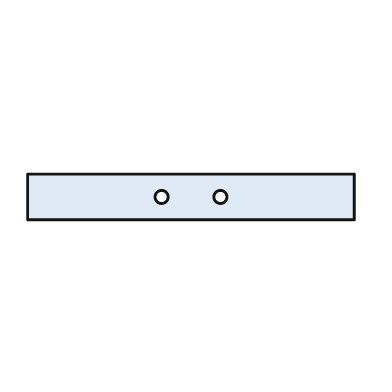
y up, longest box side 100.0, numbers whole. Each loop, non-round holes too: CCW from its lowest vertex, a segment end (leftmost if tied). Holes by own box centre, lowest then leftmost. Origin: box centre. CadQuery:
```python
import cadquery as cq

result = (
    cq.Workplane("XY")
    .moveTo(-50.0, -7.0)
    .lineTo(50.0, -7.0)
    .lineTo(50.0, 7.0)
    .lineTo(-50.0, 7.0)
    .close()
    .moveTo(-9.0, 0.0)
    .circle(2.0)
    .moveTo(9.0, 0.0)
    .circle(2.0)
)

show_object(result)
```